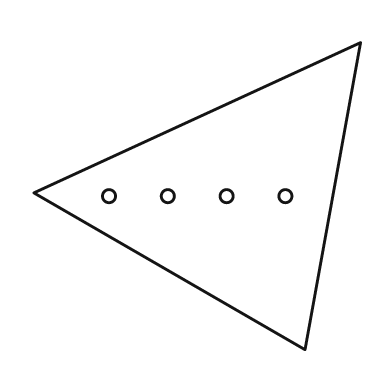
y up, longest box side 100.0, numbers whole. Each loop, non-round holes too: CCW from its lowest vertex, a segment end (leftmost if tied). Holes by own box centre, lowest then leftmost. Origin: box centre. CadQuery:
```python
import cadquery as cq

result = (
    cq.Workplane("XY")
    .moveTo(33.0, -47.0)
    .lineTo(50.0, 47.0)
    .lineTo(-50.0, 1.0)
    .close()
    .moveTo(-27.0, 0.0)
    .circle(2.0)
    .moveTo(-9.0, 0.0)
    .circle(2.0)
    .moveTo(9.0, 0.0)
    .circle(2.0)
    .moveTo(27.0, 0.0)
    .circle(2.0)
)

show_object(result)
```